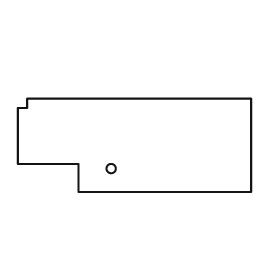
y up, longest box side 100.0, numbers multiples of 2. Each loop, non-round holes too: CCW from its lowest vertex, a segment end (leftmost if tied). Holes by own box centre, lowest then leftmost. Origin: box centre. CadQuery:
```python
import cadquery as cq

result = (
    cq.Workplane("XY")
    .moveTo(-24.0, -20.0)
    .lineTo(50.0, -20.0)
    .lineTo(50.0, 20.0)
    .lineTo(-46.0, 20.0)
    .lineTo(-46.0, 16.0)
    .lineTo(-50.0, 16.0)
    .lineTo(-50.0, -8.0)
    .lineTo(-24.0, -8.0)
    .close()
    .moveTo(-10.0, -10.0)
    .circle(2.0)
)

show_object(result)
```